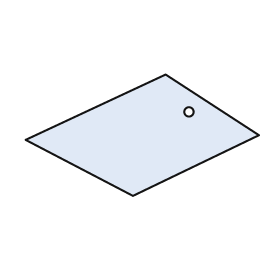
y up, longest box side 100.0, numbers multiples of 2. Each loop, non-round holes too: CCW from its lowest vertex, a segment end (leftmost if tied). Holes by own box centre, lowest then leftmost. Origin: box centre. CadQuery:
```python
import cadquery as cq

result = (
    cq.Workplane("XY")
    .moveTo(-4.0, -26.0)
    .lineTo(50.0, 0.0)
    .lineTo(10.0, 26.0)
    .lineTo(-50.0, -2.0)
    .close()
    .moveTo(20.0, 10.0)
    .circle(2.0)
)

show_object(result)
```